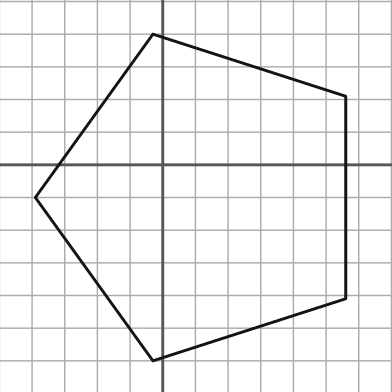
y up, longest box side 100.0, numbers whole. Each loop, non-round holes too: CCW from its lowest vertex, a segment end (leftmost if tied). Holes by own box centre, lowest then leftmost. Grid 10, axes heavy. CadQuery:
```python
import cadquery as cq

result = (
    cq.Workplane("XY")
    .moveTo(-3.0, -60.0)
    .lineTo(56.0, -41.0)
    .lineTo(56.0, 21.0)
    .lineTo(-3.0, 40.0)
    .lineTo(-39.0, -10.0)
    .close()
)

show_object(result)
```